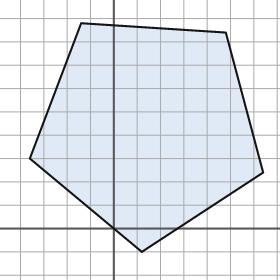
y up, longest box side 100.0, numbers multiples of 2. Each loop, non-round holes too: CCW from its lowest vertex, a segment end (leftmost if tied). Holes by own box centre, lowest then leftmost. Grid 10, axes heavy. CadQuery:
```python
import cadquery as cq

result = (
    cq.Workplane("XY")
    .moveTo(12.0, -10.0)
    .lineTo(64.0, 24.0)
    .lineTo(48.0, 84.0)
    .lineTo(-14.0, 88.0)
    .lineTo(-36.0, 30.0)
    .close()
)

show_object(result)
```